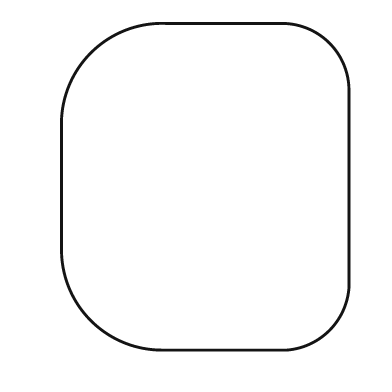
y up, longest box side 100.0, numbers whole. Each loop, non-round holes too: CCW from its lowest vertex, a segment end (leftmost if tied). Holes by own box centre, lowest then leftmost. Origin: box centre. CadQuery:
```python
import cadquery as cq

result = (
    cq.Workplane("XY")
    .moveTo(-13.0, -50.0)
    .lineTo(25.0, -50.0)
    .threePointArc((38.0, -44.0), (44.0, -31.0))
    .lineTo(44.0, 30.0)
    .threePointArc((38.0, 44.0), (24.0, 50.0))
    .lineTo(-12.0, 50.0)
    .threePointArc((-35.0, 41.0), (-44.0, 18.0))
    .lineTo(-44.0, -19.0)
    .threePointArc((-35.0, -41.0), (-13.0, -50.0))
    .close()
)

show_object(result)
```